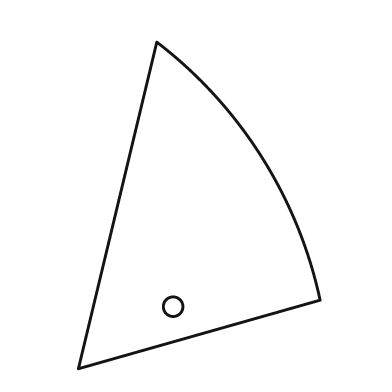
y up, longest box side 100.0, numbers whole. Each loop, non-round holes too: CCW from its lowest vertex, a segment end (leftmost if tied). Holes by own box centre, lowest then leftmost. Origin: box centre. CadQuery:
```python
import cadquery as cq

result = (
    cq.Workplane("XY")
    .moveTo(-37.0, -50.0)
    .lineTo(37.0, -29.0)
    .threePointArc((19.0, 15.0), (-13.0, 50.0))
    .close()
    .moveTo(-8.0, -31.0)
    .circle(3.0)
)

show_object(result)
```